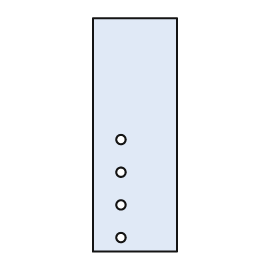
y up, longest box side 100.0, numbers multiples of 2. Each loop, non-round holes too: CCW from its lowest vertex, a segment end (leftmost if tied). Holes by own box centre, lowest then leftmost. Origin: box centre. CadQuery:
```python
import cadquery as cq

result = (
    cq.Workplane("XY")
    .moveTo(-18.0, -50.0)
    .lineTo(18.0, -50.0)
    .lineTo(18.0, 50.0)
    .lineTo(-18.0, 50.0)
    .close()
    .moveTo(-6.0, -44.0)
    .circle(2.0)
    .moveTo(-6.0, -30.0)
    .circle(2.0)
    .moveTo(-6.0, -16.0)
    .circle(2.0)
    .moveTo(-6.0, -2.0)
    .circle(2.0)
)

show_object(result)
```